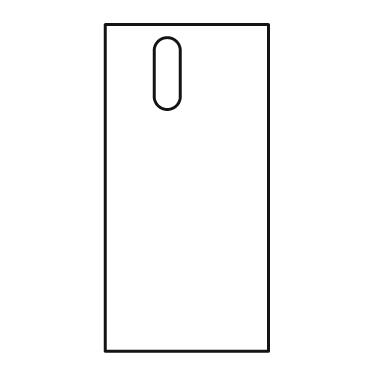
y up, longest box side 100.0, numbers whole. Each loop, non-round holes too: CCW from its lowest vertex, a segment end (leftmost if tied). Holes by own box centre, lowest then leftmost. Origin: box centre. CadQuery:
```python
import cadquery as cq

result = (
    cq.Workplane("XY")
    .moveTo(-25.0, -50.0)
    .lineTo(25.0, -50.0)
    .lineTo(25.0, 50.0)
    .lineTo(-25.0, 50.0)
    .close()
    .moveTo(-10.0, 28.0)
    .threePointArc((-6.0, 24.0), (-2.0, 28.0))
    .lineTo(-2.0, 42.0)
    .threePointArc((-6.0, 46.0), (-10.0, 42.0))
    .close()
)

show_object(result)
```